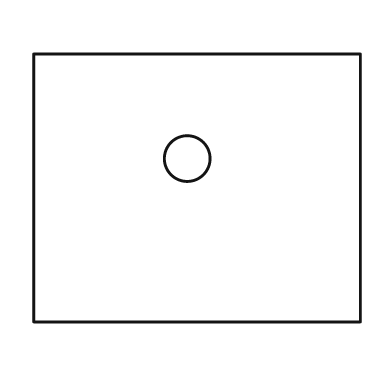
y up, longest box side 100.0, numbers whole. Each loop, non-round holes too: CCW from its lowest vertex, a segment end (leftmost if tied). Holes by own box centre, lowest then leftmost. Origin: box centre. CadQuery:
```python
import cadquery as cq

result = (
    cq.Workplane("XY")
    .moveTo(-50.0, -41.0)
    .lineTo(50.0, -41.0)
    .lineTo(50.0, 41.0)
    .lineTo(-50.0, 41.0)
    .close()
    .moveTo(-3.0, 9.0)
    .circle(7.0)
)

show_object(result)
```